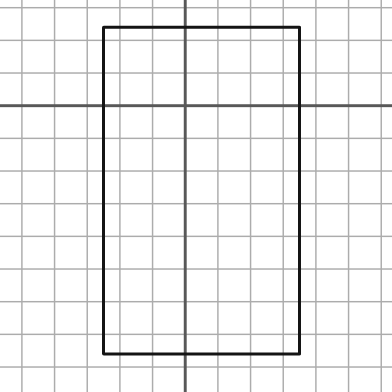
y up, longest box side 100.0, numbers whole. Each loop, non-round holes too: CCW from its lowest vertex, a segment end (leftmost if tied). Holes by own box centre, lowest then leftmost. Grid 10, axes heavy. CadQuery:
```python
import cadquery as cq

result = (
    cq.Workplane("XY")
    .moveTo(-25.0, -76.0)
    .lineTo(35.0, -76.0)
    .lineTo(35.0, 24.0)
    .lineTo(-25.0, 24.0)
    .close()
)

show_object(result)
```